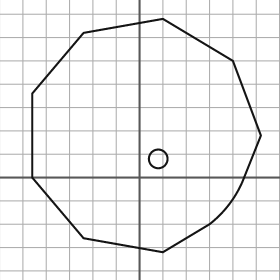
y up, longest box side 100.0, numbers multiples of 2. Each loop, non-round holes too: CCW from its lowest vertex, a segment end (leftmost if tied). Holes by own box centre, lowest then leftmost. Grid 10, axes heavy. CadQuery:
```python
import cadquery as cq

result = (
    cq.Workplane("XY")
    .moveTo(10.0, -32.0)
    .lineTo(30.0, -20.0)
    .threePointArc((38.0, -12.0), (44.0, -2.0))
    .lineTo(52.0, 18.0)
    .lineTo(40.0, 50.0)
    .lineTo(10.0, 68.0)
    .lineTo(-24.0, 62.0)
    .lineTo(-46.0, 36.0)
    .lineTo(-46.0, 0.0)
    .lineTo(-24.0, -26.0)
    .close()
    .moveTo(8.0, 8.0)
    .circle(4.0)
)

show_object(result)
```